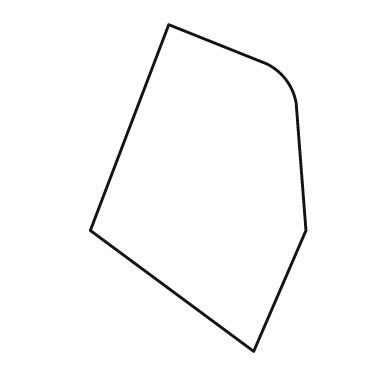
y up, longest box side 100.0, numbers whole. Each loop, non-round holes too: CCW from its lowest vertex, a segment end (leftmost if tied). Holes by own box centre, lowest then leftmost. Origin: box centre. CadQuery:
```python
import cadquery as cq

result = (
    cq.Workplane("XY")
    .moveTo(17.0, -50.0)
    .lineTo(33.0, -13.0)
    .lineTo(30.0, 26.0)
    .threePointArc((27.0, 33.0), (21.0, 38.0))
    .lineTo(-9.0, 50.0)
    .lineTo(-33.0, -13.0)
    .close()
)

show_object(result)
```